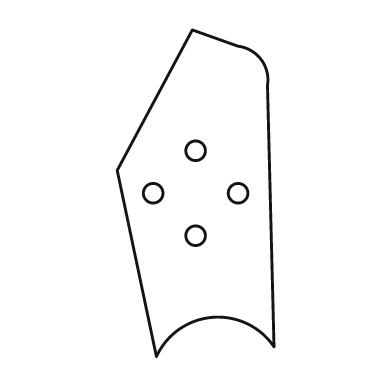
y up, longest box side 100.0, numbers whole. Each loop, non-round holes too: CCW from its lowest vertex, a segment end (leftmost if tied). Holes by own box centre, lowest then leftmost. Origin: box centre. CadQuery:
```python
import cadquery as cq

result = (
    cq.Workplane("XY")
    .moveTo(-12.0, -50.0)
    .threePointArc((5.0, -38.0), (24.0, -47.0))
    .lineTo(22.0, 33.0)
    .threePointArc((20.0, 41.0), (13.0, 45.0))
    .lineTo(-1.0, 50.0)
    .lineTo(-24.0, 7.0)
    .close()
    .moveTo(0.0, -13.0)
    .circle(3.0)
    .moveTo(-13.0, 0.0)
    .circle(3.0)
    .moveTo(13.0, 0.0)
    .circle(3.0)
    .moveTo(0.0, 13.0)
    .circle(3.0)
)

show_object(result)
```